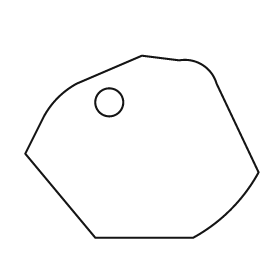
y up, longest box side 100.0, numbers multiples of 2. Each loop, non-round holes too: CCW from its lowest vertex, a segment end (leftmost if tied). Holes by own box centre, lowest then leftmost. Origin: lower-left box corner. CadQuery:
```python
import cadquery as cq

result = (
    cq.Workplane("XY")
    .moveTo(30.0, 0.0)
    .lineTo(72.0, 0.0)
    .threePointArc((88.0, 12.0), (100.0, 28.0))
    .lineTo(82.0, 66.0)
    .threePointArc((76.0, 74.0), (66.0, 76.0))
    .lineTo(50.0, 78.0)
    .lineTo(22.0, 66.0)
    .threePointArc((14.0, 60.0), (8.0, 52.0))
    .lineTo(0.0, 36.0)
    .close()
    .moveTo(36.0, 58.0)
    .circle(6.0)
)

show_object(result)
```